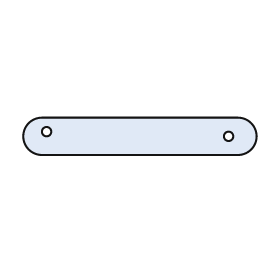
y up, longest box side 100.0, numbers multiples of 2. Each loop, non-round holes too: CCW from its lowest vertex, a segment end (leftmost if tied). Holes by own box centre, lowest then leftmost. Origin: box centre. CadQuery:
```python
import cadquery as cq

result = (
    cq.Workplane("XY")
    .moveTo(-42.0, -8.0)
    .lineTo(42.0, -8.0)
    .threePointArc((50.0, 0.0), (42.0, 8.0))
    .lineTo(-42.0, 8.0)
    .threePointArc((-50.0, 0.0), (-42.0, -8.0))
    .close()
    .moveTo(38.0, 0.0)
    .circle(2.0)
    .moveTo(-40.0, 2.0)
    .circle(2.0)
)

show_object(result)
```